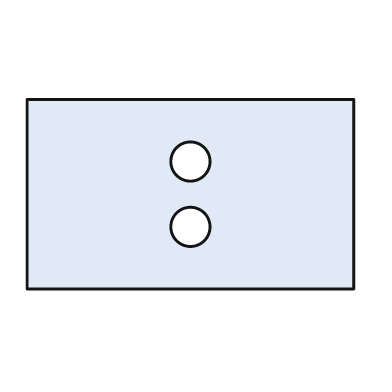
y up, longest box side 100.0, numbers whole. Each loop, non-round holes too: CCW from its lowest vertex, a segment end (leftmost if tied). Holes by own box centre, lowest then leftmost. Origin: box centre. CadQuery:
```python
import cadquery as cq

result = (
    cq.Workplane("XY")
    .moveTo(-50.0, -29.0)
    .lineTo(50.0, -29.0)
    .lineTo(50.0, 29.0)
    .lineTo(-50.0, 29.0)
    .close()
    .moveTo(0.0, -10.0)
    .circle(6.0)
    .moveTo(0.0, 10.0)
    .circle(6.0)
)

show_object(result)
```